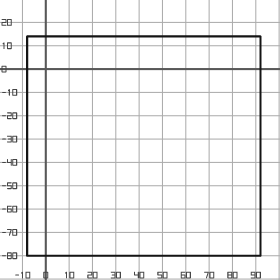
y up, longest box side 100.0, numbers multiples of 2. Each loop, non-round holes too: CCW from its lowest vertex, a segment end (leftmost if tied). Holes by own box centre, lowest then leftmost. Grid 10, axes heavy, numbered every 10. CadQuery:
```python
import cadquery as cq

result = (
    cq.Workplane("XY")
    .moveTo(-8.0, -80.0)
    .lineTo(92.0, -80.0)
    .lineTo(92.0, 14.0)
    .lineTo(-8.0, 14.0)
    .close()
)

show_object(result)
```